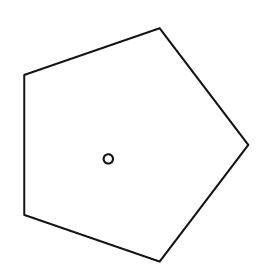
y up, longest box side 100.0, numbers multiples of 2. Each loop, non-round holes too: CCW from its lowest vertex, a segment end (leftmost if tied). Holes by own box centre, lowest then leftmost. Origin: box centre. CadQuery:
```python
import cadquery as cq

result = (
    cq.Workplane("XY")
    .moveTo(10.0, -50.0)
    .lineTo(48.0, 0.0)
    .lineTo(10.0, 50.0)
    .lineTo(-48.0, 30.0)
    .lineTo(-48.0, -30.0)
    .close()
    .moveTo(-12.0, -6.0)
    .circle(2.0)
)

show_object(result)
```